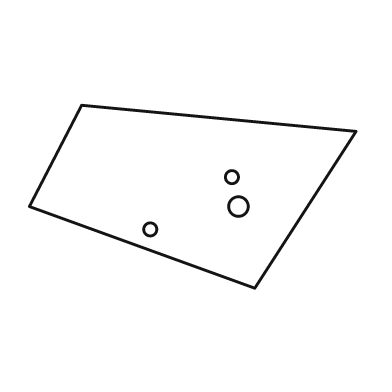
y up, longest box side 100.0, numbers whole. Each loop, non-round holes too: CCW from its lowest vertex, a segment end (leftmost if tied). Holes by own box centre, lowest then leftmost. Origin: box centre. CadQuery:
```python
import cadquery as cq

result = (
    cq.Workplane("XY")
    .moveTo(19.0, -28.0)
    .lineTo(50.0, 20.0)
    .lineTo(-34.0, 28.0)
    .lineTo(-50.0, -3.0)
    .close()
    .moveTo(-13.0, -10.0)
    .circle(2.0)
    .moveTo(14.0, -3.0)
    .circle(3.0)
    .moveTo(12.0, 6.0)
    .circle(2.0)
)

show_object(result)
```